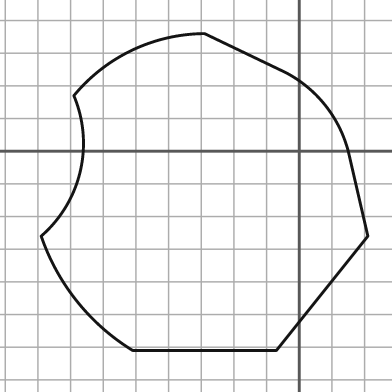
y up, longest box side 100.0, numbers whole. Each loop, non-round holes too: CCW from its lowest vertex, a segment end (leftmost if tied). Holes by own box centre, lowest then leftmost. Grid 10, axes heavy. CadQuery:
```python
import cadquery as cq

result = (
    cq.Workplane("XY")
    .moveTo(-51.0, -61.0)
    .lineTo(-7.0, -61.0)
    .lineTo(21.0, -26.0)
    .lineTo(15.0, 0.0)
    .threePointArc((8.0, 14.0), (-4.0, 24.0))
    .lineTo(-29.0, 36.0)
    .threePointArc((-51.0, 31.0), (-69.0, 17.0))
    .threePointArc((-67.0, -6.0), (-79.0, -26.0))
    .threePointArc((-68.0, -46.0), (-51.0, -61.0))
    .close()
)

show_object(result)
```